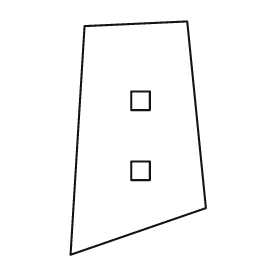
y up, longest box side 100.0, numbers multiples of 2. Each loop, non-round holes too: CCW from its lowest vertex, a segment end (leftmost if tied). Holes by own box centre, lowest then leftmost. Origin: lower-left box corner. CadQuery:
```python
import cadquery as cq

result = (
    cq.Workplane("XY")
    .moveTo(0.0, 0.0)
    .lineTo(58.0, 20.0)
    .lineTo(50.0, 100.0)
    .lineTo(6.0, 98.0)
    .close()
    .moveTo(26.0, 32.0)
    .lineTo(34.0, 32.0)
    .lineTo(34.0, 40.0)
    .lineTo(26.0, 40.0)
    .close()
    .moveTo(26.0, 62.0)
    .lineTo(34.0, 62.0)
    .lineTo(34.0, 70.0)
    .lineTo(26.0, 70.0)
    .close()
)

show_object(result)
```